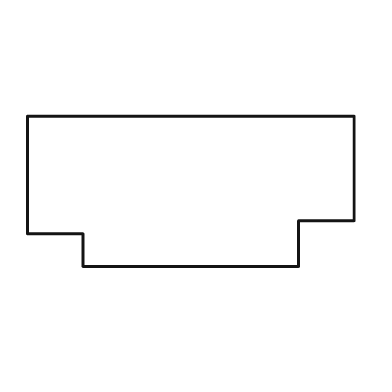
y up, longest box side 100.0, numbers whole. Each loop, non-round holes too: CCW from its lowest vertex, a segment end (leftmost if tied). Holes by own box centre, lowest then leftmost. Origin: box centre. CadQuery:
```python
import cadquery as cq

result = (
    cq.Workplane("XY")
    .moveTo(-33.0, -23.0)
    .lineTo(33.0, -23.0)
    .lineTo(33.0, -9.0)
    .lineTo(50.0, -9.0)
    .lineTo(50.0, 23.0)
    .lineTo(-50.0, 23.0)
    .lineTo(-50.0, -13.0)
    .lineTo(-33.0, -13.0)
    .close()
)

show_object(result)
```